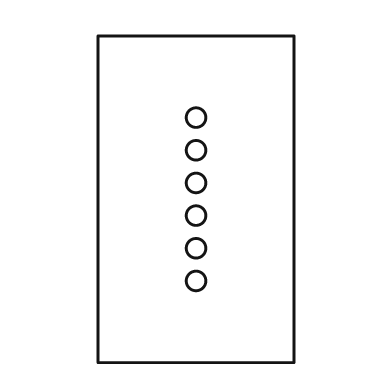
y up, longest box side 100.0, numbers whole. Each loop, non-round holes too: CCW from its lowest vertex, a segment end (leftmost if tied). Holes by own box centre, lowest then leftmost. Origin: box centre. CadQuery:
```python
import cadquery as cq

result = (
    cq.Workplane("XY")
    .moveTo(-30.0, -50.0)
    .lineTo(30.0, -50.0)
    .lineTo(30.0, 50.0)
    .lineTo(-30.0, 50.0)
    .close()
    .moveTo(0.0, -25.0)
    .circle(3.0)
    .moveTo(0.0, -15.0)
    .circle(3.0)
    .moveTo(0.0, -5.0)
    .circle(3.0)
    .moveTo(0.0, 5.0)
    .circle(3.0)
    .moveTo(0.0, 15.0)
    .circle(3.0)
    .moveTo(0.0, 25.0)
    .circle(3.0)
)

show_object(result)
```